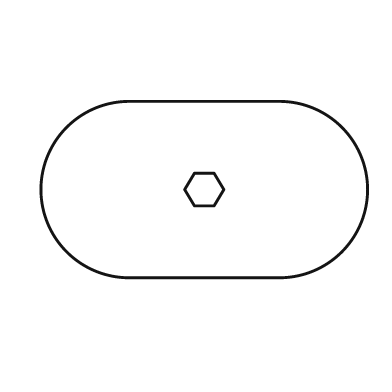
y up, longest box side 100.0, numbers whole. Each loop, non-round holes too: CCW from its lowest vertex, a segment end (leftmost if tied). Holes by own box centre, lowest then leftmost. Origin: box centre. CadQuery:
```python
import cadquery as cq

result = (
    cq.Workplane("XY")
    .moveTo(-23.0, -27.0)
    .lineTo(23.0, -27.0)
    .threePointArc((50.0, 0.0), (23.0, 27.0))
    .lineTo(-23.0, 27.0)
    .threePointArc((-50.0, 0.0), (-23.0, -27.0))
    .close()
    .moveTo(-3.0, -5.0)
    .lineTo(3.0, -5.0)
    .lineTo(6.0, 0.0)
    .lineTo(3.0, 5.0)
    .lineTo(-3.0, 5.0)
    .lineTo(-6.0, 0.0)
    .close()
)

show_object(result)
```